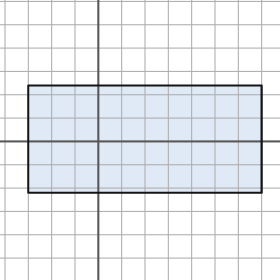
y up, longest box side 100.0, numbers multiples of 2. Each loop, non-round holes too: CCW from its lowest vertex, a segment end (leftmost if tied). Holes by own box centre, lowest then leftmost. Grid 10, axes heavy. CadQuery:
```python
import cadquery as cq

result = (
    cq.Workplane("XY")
    .moveTo(-30.0, -22.0)
    .lineTo(70.0, -22.0)
    .lineTo(70.0, 24.0)
    .lineTo(-30.0, 24.0)
    .close()
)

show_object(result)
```